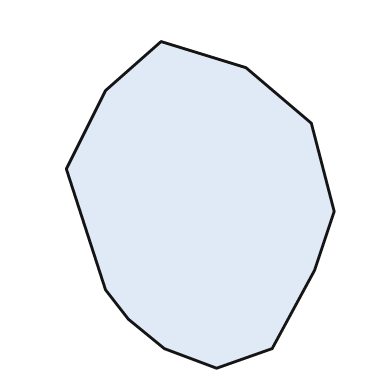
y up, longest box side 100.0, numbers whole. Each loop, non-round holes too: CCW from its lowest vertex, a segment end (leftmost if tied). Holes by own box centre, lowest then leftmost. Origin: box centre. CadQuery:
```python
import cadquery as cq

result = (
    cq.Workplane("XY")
    .moveTo(5.0, -50.0)
    .lineTo(22.0, -44.0)
    .lineTo(35.0, -20.0)
    .lineTo(41.0, -2.0)
    .lineTo(34.0, 25.0)
    .lineTo(14.0, 42.0)
    .lineTo(-12.0, 50.0)
    .lineTo(-29.0, 35.0)
    .lineTo(-41.0, 11.0)
    .lineTo(-29.0, -26.0)
    .lineTo(-22.0, -35.0)
    .lineTo(-11.0, -44.0)
    .close()
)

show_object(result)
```